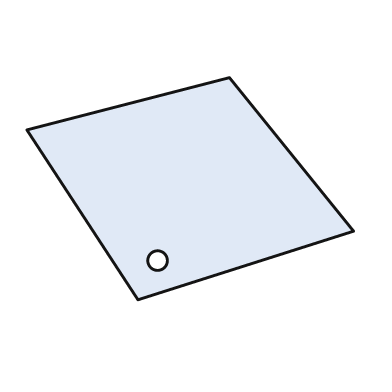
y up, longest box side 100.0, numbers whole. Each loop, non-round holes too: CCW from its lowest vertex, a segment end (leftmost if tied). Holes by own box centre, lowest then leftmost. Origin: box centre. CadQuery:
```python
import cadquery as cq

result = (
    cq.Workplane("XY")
    .moveTo(-16.0, -34.0)
    .lineTo(50.0, -13.0)
    .lineTo(12.0, 34.0)
    .lineTo(-50.0, 18.0)
    .close()
    .moveTo(-10.0, -22.0)
    .circle(3.0)
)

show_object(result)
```